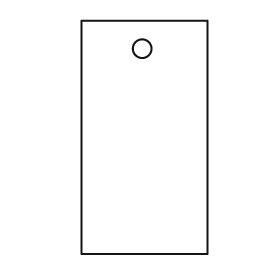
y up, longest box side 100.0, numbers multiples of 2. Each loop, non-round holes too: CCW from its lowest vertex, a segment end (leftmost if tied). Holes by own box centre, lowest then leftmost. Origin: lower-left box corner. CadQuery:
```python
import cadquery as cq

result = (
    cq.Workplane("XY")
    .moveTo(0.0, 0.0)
    .lineTo(54.0, 0.0)
    .lineTo(54.0, 100.0)
    .lineTo(0.0, 100.0)
    .close()
    .moveTo(26.0, 88.0)
    .circle(4.0)
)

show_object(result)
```